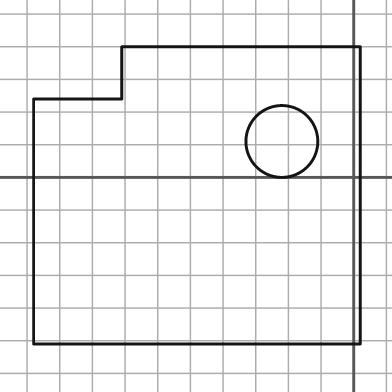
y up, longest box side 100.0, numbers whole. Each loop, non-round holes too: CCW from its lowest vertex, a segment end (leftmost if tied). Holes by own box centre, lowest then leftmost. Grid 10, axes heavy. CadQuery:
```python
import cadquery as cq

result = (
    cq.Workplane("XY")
    .moveTo(-98.0, -51.0)
    .lineTo(2.0, -51.0)
    .lineTo(2.0, 40.0)
    .lineTo(-71.0, 40.0)
    .lineTo(-71.0, 24.0)
    .lineTo(-98.0, 24.0)
    .close()
    .moveTo(-22.0, 11.0)
    .circle(11.0)
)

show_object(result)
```